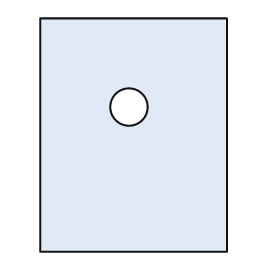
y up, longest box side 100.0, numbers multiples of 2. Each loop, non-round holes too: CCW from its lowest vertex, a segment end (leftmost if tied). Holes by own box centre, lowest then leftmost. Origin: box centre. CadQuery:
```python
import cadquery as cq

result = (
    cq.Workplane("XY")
    .moveTo(-40.0, -50.0)
    .lineTo(40.0, -50.0)
    .lineTo(40.0, 50.0)
    .lineTo(-40.0, 50.0)
    .close()
    .moveTo(-2.0, 12.0)
    .circle(8.0)
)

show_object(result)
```